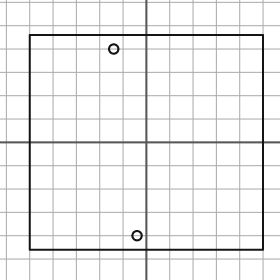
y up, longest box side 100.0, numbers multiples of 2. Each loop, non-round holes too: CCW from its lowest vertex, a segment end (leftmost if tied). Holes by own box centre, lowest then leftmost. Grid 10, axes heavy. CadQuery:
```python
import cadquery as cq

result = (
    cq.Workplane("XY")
    .moveTo(-50.0, -46.0)
    .lineTo(50.0, -46.0)
    .lineTo(50.0, 46.0)
    .lineTo(-50.0, 46.0)
    .close()
    .moveTo(-4.0, -40.0)
    .circle(2.0)
    .moveTo(-14.0, 40.0)
    .circle(2.0)
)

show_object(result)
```